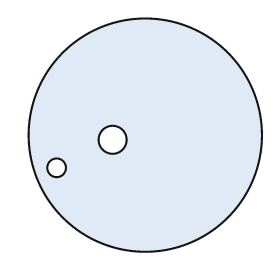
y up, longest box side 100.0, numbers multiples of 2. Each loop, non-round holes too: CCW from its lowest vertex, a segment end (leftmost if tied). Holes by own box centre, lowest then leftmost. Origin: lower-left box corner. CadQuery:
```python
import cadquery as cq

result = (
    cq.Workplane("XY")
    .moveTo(50.0, 50.0)
    .circle(50.0)
    .moveTo(12.0, 36.0)
    .circle(4.0)
    .moveTo(36.0, 48.0)
    .circle(6.0)
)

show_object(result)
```